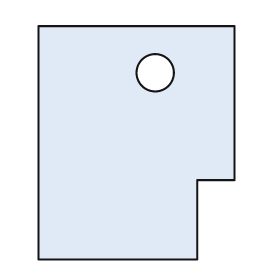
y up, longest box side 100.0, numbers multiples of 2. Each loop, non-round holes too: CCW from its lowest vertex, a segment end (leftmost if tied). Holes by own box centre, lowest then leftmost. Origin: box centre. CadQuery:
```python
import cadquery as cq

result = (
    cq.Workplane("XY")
    .moveTo(-42.0, -50.0)
    .lineTo(26.0, -50.0)
    .lineTo(26.0, -16.0)
    .lineTo(42.0, -16.0)
    .lineTo(42.0, 50.0)
    .lineTo(-42.0, 50.0)
    .close()
    .moveTo(8.0, 30.0)
    .circle(8.0)
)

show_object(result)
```